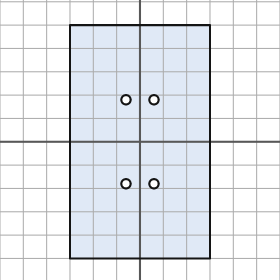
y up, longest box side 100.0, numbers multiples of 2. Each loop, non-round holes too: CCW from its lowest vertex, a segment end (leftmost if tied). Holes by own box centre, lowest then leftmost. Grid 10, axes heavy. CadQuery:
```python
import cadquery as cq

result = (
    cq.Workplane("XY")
    .moveTo(-30.0, -50.0)
    .lineTo(30.0, -50.0)
    .lineTo(30.0, 50.0)
    .lineTo(-30.0, 50.0)
    .close()
    .moveTo(-6.0, -18.0)
    .circle(2.0)
    .moveTo(6.0, -18.0)
    .circle(2.0)
    .moveTo(-6.0, 18.0)
    .circle(2.0)
    .moveTo(6.0, 18.0)
    .circle(2.0)
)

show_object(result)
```